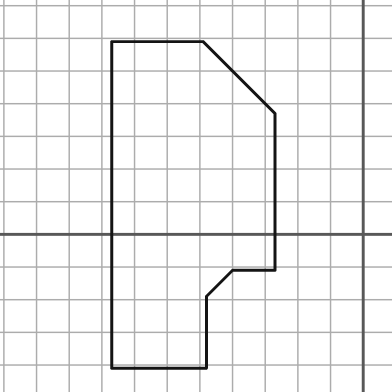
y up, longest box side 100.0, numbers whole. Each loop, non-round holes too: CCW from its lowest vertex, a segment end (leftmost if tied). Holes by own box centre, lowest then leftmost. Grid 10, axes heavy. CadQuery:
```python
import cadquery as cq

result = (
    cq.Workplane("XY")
    .moveTo(-77.0, -41.0)
    .lineTo(-48.0, -41.0)
    .lineTo(-48.0, -19.0)
    .lineTo(-40.0, -11.0)
    .lineTo(-27.0, -11.0)
    .lineTo(-27.0, 37.0)
    .lineTo(-49.0, 59.0)
    .lineTo(-77.0, 59.0)
    .close()
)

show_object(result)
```